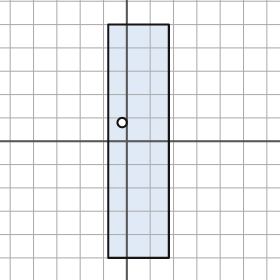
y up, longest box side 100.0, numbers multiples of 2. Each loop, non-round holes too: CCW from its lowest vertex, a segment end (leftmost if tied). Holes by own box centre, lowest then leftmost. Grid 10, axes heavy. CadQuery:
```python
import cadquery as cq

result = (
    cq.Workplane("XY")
    .moveTo(-8.0, -50.0)
    .lineTo(18.0, -50.0)
    .lineTo(18.0, 50.0)
    .lineTo(-8.0, 50.0)
    .close()
    .moveTo(-2.0, 8.0)
    .circle(2.0)
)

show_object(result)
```